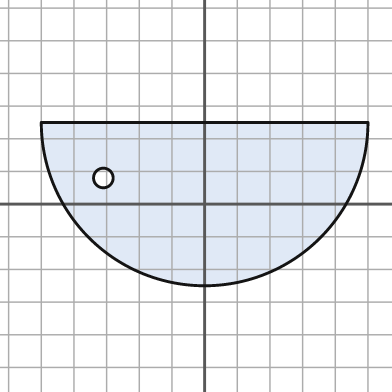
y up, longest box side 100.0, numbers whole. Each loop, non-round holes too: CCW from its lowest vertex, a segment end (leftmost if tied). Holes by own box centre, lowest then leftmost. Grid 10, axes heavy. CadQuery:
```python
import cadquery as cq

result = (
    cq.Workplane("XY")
    .moveTo(-50.0, 25.0)
    .threePointArc((0.0, -25.0), (50.0, 25.0))
    .close()
    .moveTo(-31.0, 8.0)
    .circle(3.0)
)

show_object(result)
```